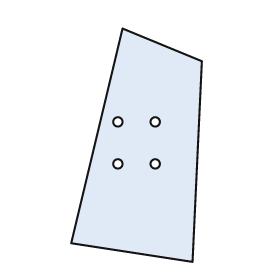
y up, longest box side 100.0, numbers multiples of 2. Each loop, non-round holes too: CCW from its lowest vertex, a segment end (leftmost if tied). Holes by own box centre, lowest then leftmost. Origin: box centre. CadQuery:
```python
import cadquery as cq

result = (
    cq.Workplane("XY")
    .moveTo(24.0, -50.0)
    .lineTo(28.0, 36.0)
    .lineTo(-6.0, 50.0)
    .lineTo(-28.0, -42.0)
    .close()
    .moveTo(-8.0, -8.0)
    .circle(2.0)
    .moveTo(8.0, -8.0)
    .circle(2.0)
    .moveTo(-8.0, 10.0)
    .circle(2.0)
    .moveTo(8.0, 10.0)
    .circle(2.0)
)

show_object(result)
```